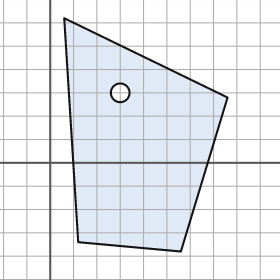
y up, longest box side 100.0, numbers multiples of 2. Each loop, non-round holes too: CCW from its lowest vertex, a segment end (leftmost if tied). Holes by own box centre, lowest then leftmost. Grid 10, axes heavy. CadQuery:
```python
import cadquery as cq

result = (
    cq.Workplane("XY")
    .moveTo(56.0, -38.0)
    .lineTo(76.0, 28.0)
    .lineTo(6.0, 62.0)
    .lineTo(12.0, -34.0)
    .close()
    .moveTo(30.0, 30.0)
    .circle(4.0)
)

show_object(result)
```